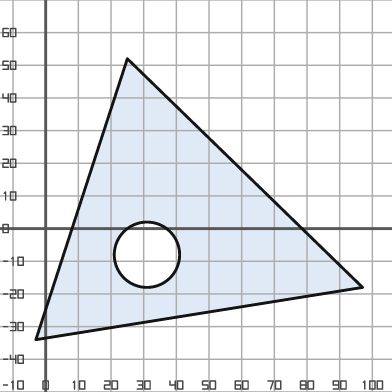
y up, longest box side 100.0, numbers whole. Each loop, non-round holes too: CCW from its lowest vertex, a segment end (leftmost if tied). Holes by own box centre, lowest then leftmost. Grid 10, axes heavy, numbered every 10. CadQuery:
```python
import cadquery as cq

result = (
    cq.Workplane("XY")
    .moveTo(-3.0, -34.0)
    .lineTo(97.0, -18.0)
    .lineTo(25.0, 52.0)
    .close()
    .moveTo(31.0, -8.0)
    .circle(10.0)
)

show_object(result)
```